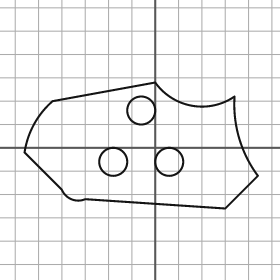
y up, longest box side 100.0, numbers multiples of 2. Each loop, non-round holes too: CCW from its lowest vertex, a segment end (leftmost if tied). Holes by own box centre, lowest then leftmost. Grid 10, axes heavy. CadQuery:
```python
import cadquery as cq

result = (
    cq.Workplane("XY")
    .moveTo(30.0, -26.0)
    .lineTo(44.0, -12.0)
    .threePointArc((36.0, 4.0), (34.0, 22.0))
    .threePointArc((16.0, 18.0), (0.0, 28.0))
    .lineTo(-44.0, 20.0)
    .threePointArc((-52.0, 10.0), (-56.0, -2.0))
    .lineTo(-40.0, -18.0)
    .threePointArc((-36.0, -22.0), (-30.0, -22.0))
    .close()
    .moveTo(-18.0, -6.0)
    .circle(6.0)
    .moveTo(6.0, -6.0)
    .circle(6.0)
    .moveTo(-6.0, 16.0)
    .circle(6.0)
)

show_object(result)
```